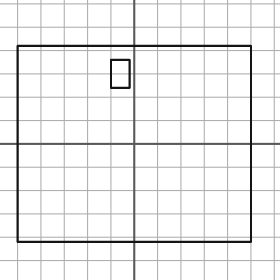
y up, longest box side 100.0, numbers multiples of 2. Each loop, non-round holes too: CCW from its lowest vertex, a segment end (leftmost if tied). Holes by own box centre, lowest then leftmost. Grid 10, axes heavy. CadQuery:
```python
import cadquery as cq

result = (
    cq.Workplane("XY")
    .moveTo(-50.0, -42.0)
    .lineTo(50.0, -42.0)
    .lineTo(50.0, 42.0)
    .lineTo(-50.0, 42.0)
    .close()
    .moveTo(-10.0, 24.0)
    .lineTo(-2.0, 24.0)
    .lineTo(-2.0, 36.0)
    .lineTo(-10.0, 36.0)
    .close()
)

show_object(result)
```